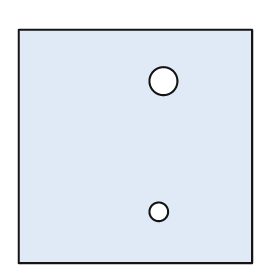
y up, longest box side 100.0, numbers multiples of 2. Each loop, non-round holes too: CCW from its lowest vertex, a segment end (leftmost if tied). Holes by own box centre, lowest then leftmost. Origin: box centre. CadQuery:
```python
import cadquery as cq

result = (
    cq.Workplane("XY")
    .moveTo(-50.0, -50.0)
    .lineTo(50.0, -50.0)
    .lineTo(50.0, 50.0)
    .lineTo(-50.0, 50.0)
    .close()
    .moveTo(10.0, -28.0)
    .circle(4.0)
    .moveTo(12.0, 28.0)
    .circle(6.0)
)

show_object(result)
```